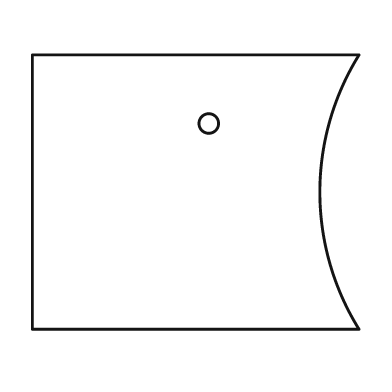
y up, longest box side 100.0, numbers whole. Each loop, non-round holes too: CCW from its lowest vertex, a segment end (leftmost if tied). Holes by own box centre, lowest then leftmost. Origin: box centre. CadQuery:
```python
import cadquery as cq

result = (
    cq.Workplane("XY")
    .moveTo(-50.0, -42.0)
    .lineTo(50.0, -42.0)
    .threePointArc((38.0, 0.0), (50.0, 42.0))
    .lineTo(-50.0, 42.0)
    .close()
    .moveTo(4.0, 21.0)
    .circle(3.0)
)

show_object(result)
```